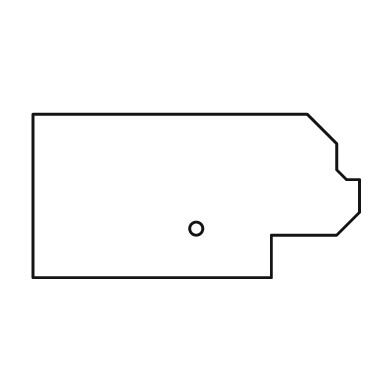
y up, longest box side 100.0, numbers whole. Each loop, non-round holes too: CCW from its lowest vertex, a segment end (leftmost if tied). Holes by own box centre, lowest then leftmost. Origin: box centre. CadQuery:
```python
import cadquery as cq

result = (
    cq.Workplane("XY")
    .moveTo(-50.0, -25.0)
    .lineTo(23.0, -25.0)
    .lineTo(23.0, -12.0)
    .lineTo(43.0, -12.0)
    .lineTo(50.0, -5.0)
    .lineTo(50.0, 5.0)
    .lineTo(46.0, 5.0)
    .lineTo(43.0, 8.0)
    .lineTo(43.0, 16.0)
    .lineTo(34.0, 25.0)
    .lineTo(-50.0, 25.0)
    .close()
    .moveTo(0.0, -10.0)
    .circle(2.0)
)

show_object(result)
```